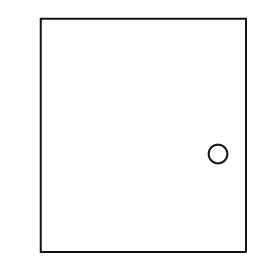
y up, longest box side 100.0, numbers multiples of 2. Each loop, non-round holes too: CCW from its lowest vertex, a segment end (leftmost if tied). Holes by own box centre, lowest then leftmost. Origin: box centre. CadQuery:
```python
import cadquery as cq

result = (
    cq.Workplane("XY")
    .moveTo(-44.0, -50.0)
    .lineTo(44.0, -50.0)
    .lineTo(44.0, 50.0)
    .lineTo(-44.0, 50.0)
    .close()
    .moveTo(32.0, -8.0)
    .circle(4.0)
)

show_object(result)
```